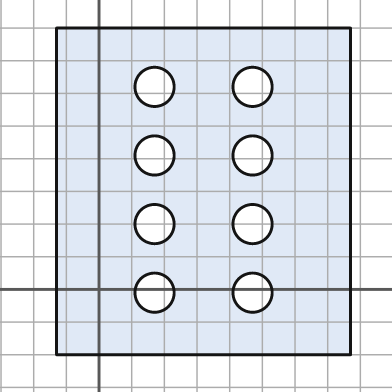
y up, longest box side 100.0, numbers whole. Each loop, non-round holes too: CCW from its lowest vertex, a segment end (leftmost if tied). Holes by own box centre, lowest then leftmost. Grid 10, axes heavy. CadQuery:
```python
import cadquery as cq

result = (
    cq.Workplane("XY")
    .moveTo(-13.0, -20.0)
    .lineTo(77.0, -20.0)
    .lineTo(77.0, 80.0)
    .lineTo(-13.0, 80.0)
    .close()
    .moveTo(17.0, -1.0)
    .circle(6.0)
    .moveTo(47.0, -1.0)
    .circle(6.0)
    .moveTo(17.0, 20.0)
    .circle(6.0)
    .moveTo(47.0, 20.0)
    .circle(6.0)
    .moveTo(17.0, 41.0)
    .circle(6.0)
    .moveTo(47.0, 41.0)
    .circle(6.0)
    .moveTo(17.0, 62.0)
    .circle(6.0)
    .moveTo(47.0, 62.0)
    .circle(6.0)
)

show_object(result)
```